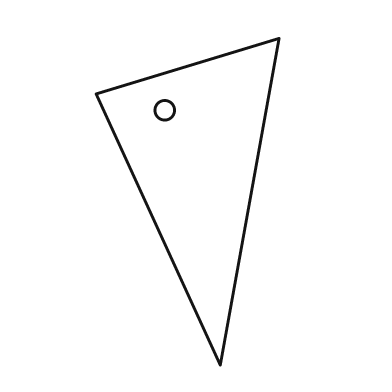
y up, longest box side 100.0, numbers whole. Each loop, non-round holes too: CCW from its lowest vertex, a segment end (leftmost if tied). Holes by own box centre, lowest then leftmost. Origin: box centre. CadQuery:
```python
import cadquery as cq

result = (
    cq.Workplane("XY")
    .moveTo(10.0, -50.0)
    .lineTo(28.0, 50.0)
    .lineTo(-28.0, 33.0)
    .close()
    .moveTo(-7.0, 28.0)
    .circle(3.0)
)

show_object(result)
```